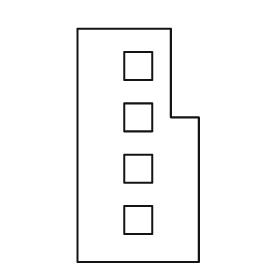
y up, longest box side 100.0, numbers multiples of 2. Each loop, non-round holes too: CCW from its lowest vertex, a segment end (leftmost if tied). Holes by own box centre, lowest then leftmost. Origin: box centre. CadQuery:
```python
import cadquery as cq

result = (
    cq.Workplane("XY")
    .moveTo(-26.0, -50.0)
    .lineTo(26.0, -50.0)
    .lineTo(26.0, 12.0)
    .lineTo(14.0, 12.0)
    .lineTo(14.0, 50.0)
    .lineTo(-26.0, 50.0)
    .close()
    .moveTo(-6.0, -38.0)
    .lineTo(6.0, -38.0)
    .lineTo(6.0, -26.0)
    .lineTo(-6.0, -26.0)
    .close()
    .moveTo(-6.0, -16.0)
    .lineTo(6.0, -16.0)
    .lineTo(6.0, -4.0)
    .lineTo(-6.0, -4.0)
    .close()
    .moveTo(-6.0, 6.0)
    .lineTo(6.0, 6.0)
    .lineTo(6.0, 18.0)
    .lineTo(-6.0, 18.0)
    .close()
    .moveTo(-6.0, 28.0)
    .lineTo(6.0, 28.0)
    .lineTo(6.0, 40.0)
    .lineTo(-6.0, 40.0)
    .close()
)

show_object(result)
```